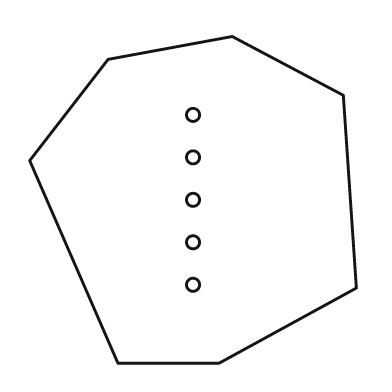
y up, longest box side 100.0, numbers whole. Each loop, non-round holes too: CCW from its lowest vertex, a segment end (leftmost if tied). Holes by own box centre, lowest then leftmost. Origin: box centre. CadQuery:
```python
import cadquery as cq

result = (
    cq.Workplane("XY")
    .moveTo(-23.0, -50.0)
    .lineTo(8.0, -50.0)
    .lineTo(50.0, -27.0)
    .lineTo(46.0, 32.0)
    .lineTo(12.0, 50.0)
    .lineTo(-26.0, 43.0)
    .lineTo(-50.0, 12.0)
    .close()
    .moveTo(0.0, -26.0)
    .circle(2.0)
    .moveTo(0.0, -13.0)
    .circle(2.0)
    .moveTo(0.0, 0.0)
    .circle(2.0)
    .moveTo(0.0, 13.0)
    .circle(2.0)
    .moveTo(0.0, 26.0)
    .circle(2.0)
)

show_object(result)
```